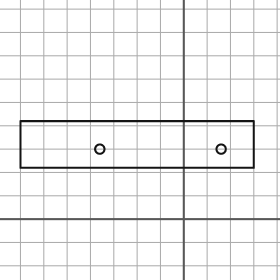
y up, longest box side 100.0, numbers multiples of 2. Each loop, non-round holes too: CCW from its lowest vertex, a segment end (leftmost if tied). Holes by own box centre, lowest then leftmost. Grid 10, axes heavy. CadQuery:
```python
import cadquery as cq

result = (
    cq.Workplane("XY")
    .moveTo(-70.0, 22.0)
    .lineTo(30.0, 22.0)
    .lineTo(30.0, 42.0)
    .lineTo(-70.0, 42.0)
    .close()
    .moveTo(-36.0, 30.0)
    .circle(2.0)
    .moveTo(16.0, 30.0)
    .circle(2.0)
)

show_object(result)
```